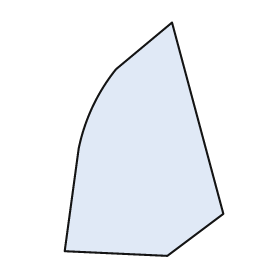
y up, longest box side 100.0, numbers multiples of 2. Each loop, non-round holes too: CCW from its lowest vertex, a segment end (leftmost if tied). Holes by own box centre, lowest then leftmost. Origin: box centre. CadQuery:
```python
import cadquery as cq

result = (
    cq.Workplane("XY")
    .moveTo(10.0, -50.0)
    .lineTo(34.0, -32.0)
    .lineTo(12.0, 50.0)
    .lineTo(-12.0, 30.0)
    .threePointArc((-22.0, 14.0), (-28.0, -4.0))
    .lineTo(-34.0, -48.0)
    .close()
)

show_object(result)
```